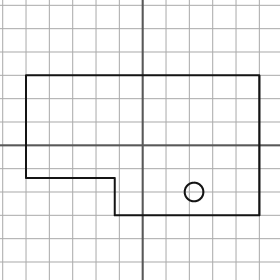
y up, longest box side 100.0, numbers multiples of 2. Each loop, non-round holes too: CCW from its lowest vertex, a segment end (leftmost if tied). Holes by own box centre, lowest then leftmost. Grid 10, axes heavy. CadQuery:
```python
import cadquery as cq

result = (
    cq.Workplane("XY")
    .moveTo(-12.0, -30.0)
    .lineTo(50.0, -30.0)
    .lineTo(50.0, 30.0)
    .lineTo(-50.0, 30.0)
    .lineTo(-50.0, -14.0)
    .lineTo(-12.0, -14.0)
    .close()
    .moveTo(22.0, -20.0)
    .circle(4.0)
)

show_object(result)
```